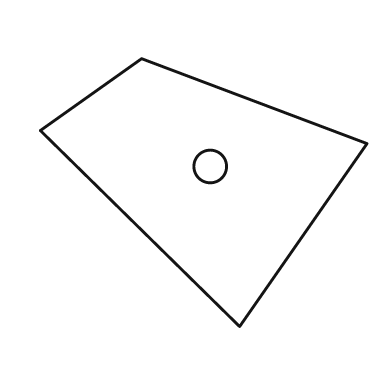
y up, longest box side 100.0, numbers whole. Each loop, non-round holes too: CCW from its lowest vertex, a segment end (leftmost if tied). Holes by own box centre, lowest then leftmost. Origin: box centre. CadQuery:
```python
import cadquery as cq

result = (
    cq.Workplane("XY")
    .moveTo(11.0, -41.0)
    .lineTo(50.0, 15.0)
    .lineTo(-19.0, 41.0)
    .lineTo(-50.0, 19.0)
    .close()
    .moveTo(2.0, 8.0)
    .circle(5.0)
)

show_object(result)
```